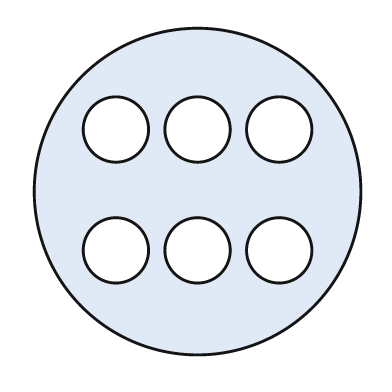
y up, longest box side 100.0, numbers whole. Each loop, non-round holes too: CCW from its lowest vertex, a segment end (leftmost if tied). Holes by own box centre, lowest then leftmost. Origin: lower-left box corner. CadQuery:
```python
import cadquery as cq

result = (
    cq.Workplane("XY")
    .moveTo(50.0, 50.0)
    .circle(50.0)
    .moveTo(25.0, 32.0)
    .circle(10.0)
    .moveTo(50.0, 32.0)
    .circle(10.0)
    .moveTo(75.0, 32.0)
    .circle(10.0)
    .moveTo(25.0, 69.0)
    .circle(10.0)
    .moveTo(50.0, 69.0)
    .circle(10.0)
    .moveTo(75.0, 69.0)
    .circle(10.0)
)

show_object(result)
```